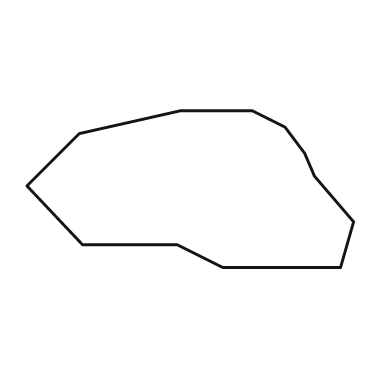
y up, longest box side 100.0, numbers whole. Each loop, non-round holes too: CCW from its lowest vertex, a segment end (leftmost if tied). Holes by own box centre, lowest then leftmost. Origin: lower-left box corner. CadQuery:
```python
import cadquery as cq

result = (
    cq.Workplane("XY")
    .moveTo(60.0, 0.0)
    .lineTo(96.0, 0.0)
    .lineTo(100.0, 14.0)
    .lineTo(88.0, 28.0)
    .lineTo(85.0, 35.0)
    .lineTo(79.0, 43.0)
    .lineTo(69.0, 48.0)
    .lineTo(47.0, 48.0)
    .lineTo(16.0, 41.0)
    .lineTo(0.0, 25.0)
    .lineTo(17.0, 7.0)
    .lineTo(46.0, 7.0)
    .close()
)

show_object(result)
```